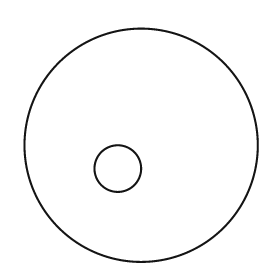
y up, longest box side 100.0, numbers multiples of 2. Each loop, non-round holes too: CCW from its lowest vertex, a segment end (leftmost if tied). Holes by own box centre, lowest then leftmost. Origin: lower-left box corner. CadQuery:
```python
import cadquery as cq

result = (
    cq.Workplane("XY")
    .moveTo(50.0, 50.0)
    .circle(50.0)
    .moveTo(40.0, 40.0)
    .circle(10.0)
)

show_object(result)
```